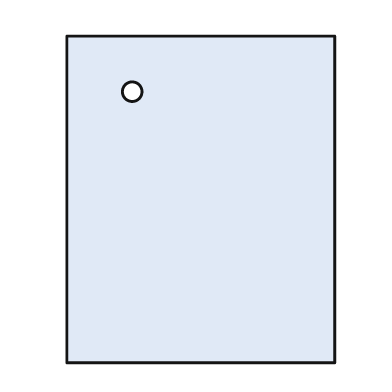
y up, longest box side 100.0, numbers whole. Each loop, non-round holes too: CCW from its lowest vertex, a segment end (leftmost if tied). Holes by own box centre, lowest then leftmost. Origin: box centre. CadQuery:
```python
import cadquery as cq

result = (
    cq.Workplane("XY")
    .moveTo(-41.0, -50.0)
    .lineTo(41.0, -50.0)
    .lineTo(41.0, 50.0)
    .lineTo(-41.0, 50.0)
    .close()
    .moveTo(-21.0, 33.0)
    .circle(3.0)
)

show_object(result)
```